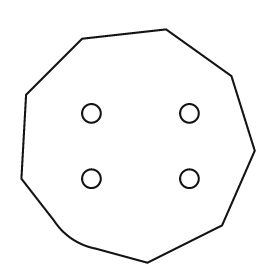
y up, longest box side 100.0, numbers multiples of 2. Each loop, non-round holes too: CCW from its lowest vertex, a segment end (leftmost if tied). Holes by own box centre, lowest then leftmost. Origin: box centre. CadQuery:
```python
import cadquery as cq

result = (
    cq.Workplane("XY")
    .moveTo(4.0, -50.0)
    .lineTo(36.0, -34.0)
    .lineTo(50.0, -2.0)
    .lineTo(40.0, 30.0)
    .lineTo(12.0, 50.0)
    .lineTo(-24.0, 46.0)
    .lineTo(-48.0, 22.0)
    .lineTo(-50.0, -14.0)
    .lineTo(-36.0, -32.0)
    .threePointArc((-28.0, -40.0), (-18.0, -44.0))
    .close()
    .moveTo(-20.0, -14.0)
    .circle(4.0)
    .moveTo(22.0, -14.0)
    .circle(4.0)
    .moveTo(-20.0, 14.0)
    .circle(4.0)
    .moveTo(22.0, 14.0)
    .circle(4.0)
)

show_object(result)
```